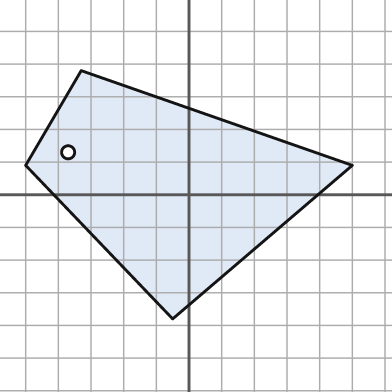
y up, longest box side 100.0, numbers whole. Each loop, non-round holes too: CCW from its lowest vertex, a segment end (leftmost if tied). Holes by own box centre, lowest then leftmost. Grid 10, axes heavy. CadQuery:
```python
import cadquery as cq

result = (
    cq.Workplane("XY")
    .moveTo(-5.0, -38.0)
    .lineTo(50.0, 9.0)
    .lineTo(-33.0, 38.0)
    .lineTo(-50.0, 9.0)
    .close()
    .moveTo(-37.0, 13.0)
    .circle(2.0)
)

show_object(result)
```